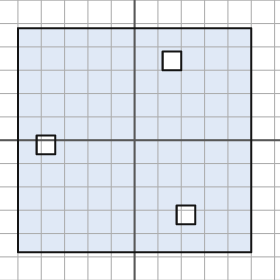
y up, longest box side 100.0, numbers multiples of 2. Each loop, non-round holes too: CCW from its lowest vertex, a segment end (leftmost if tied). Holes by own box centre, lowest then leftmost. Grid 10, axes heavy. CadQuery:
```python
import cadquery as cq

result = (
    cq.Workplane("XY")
    .moveTo(-50.0, -48.0)
    .lineTo(50.0, -48.0)
    .lineTo(50.0, 48.0)
    .lineTo(-50.0, 48.0)
    .close()
    .moveTo(18.0, -36.0)
    .lineTo(26.0, -36.0)
    .lineTo(26.0, -28.0)
    .lineTo(18.0, -28.0)
    .close()
    .moveTo(-42.0, -6.0)
    .lineTo(-34.0, -6.0)
    .lineTo(-34.0, 2.0)
    .lineTo(-42.0, 2.0)
    .close()
    .moveTo(12.0, 30.0)
    .lineTo(20.0, 30.0)
    .lineTo(20.0, 38.0)
    .lineTo(12.0, 38.0)
    .close()
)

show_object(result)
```